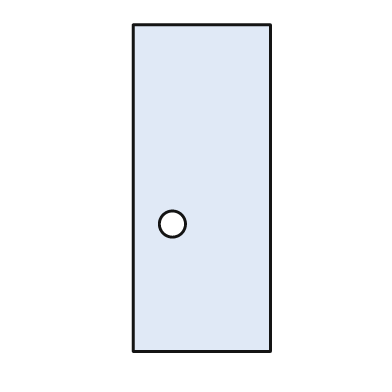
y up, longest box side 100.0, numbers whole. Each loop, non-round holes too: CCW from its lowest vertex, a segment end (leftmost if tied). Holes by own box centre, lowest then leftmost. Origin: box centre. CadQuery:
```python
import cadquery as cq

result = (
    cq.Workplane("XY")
    .moveTo(-21.0, -50.0)
    .lineTo(21.0, -50.0)
    .lineTo(21.0, 50.0)
    .lineTo(-21.0, 50.0)
    .close()
    .moveTo(-9.0, -11.0)
    .circle(4.0)
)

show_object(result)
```